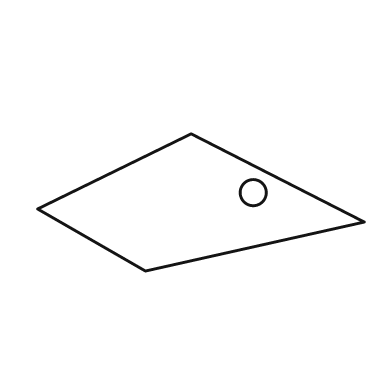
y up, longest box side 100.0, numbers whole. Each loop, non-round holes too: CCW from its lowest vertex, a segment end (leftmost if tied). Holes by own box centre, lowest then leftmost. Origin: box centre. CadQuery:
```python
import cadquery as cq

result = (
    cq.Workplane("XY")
    .moveTo(-17.0, -21.0)
    .lineTo(50.0, -6.0)
    .lineTo(-3.0, 21.0)
    .lineTo(-50.0, -2.0)
    .close()
    .moveTo(16.0, 3.0)
    .circle(4.0)
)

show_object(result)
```